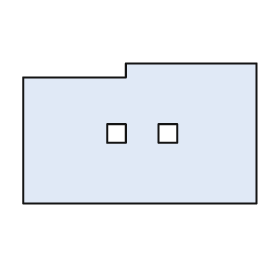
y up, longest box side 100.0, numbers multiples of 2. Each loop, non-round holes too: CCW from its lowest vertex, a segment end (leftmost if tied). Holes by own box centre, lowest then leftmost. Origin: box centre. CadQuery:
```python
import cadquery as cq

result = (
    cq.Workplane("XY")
    .moveTo(-50.0, -30.0)
    .lineTo(50.0, -30.0)
    .lineTo(50.0, 30.0)
    .lineTo(-6.0, 30.0)
    .lineTo(-6.0, 24.0)
    .lineTo(-50.0, 24.0)
    .close()
    .moveTo(-14.0, -4.0)
    .lineTo(-6.0, -4.0)
    .lineTo(-6.0, 4.0)
    .lineTo(-14.0, 4.0)
    .close()
    .moveTo(8.0, -4.0)
    .lineTo(16.0, -4.0)
    .lineTo(16.0, 4.0)
    .lineTo(8.0, 4.0)
    .close()
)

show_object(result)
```